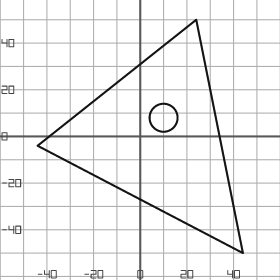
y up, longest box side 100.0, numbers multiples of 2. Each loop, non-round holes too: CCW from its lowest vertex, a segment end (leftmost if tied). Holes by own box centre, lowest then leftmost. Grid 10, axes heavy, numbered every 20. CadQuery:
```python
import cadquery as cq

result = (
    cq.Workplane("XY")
    .moveTo(44.0, -50.0)
    .lineTo(24.0, 50.0)
    .lineTo(-44.0, -4.0)
    .close()
    .moveTo(10.0, 8.0)
    .circle(6.0)
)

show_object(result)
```